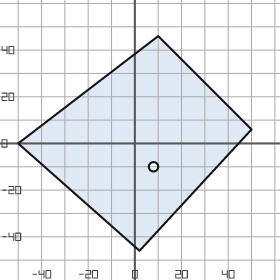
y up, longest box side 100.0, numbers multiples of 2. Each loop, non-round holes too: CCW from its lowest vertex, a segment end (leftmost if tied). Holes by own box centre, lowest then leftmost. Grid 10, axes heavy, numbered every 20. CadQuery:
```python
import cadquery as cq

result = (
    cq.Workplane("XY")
    .moveTo(2.0, -46.0)
    .lineTo(50.0, 6.0)
    .lineTo(10.0, 46.0)
    .lineTo(-50.0, 0.0)
    .close()
    .moveTo(8.0, -10.0)
    .circle(2.0)
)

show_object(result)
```